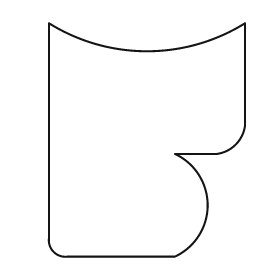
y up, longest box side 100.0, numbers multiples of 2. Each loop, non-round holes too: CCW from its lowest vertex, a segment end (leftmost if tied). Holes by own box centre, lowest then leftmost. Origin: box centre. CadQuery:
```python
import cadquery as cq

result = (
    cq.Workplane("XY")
    .moveTo(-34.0, -50.0)
    .lineTo(12.0, -50.0)
    .threePointArc((26.0, -28.0), (12.0, -6.0))
    .lineTo(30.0, -6.0)
    .threePointArc((38.0, -2.0), (42.0, 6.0))
    .lineTo(42.0, 50.0)
    .threePointArc((0.0, 38.0), (-42.0, 50.0))
    .lineTo(-42.0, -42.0)
    .threePointArc((-40.0, -48.0), (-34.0, -50.0))
    .close()
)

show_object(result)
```